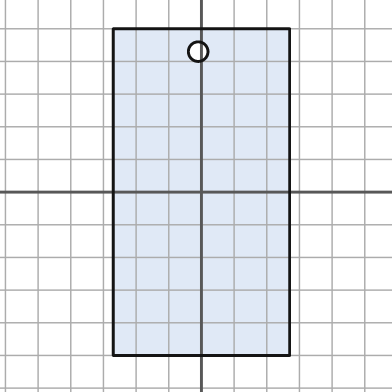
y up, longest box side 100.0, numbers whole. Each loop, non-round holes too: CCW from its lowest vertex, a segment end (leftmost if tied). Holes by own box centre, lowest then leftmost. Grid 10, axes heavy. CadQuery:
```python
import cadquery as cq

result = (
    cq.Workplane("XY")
    .moveTo(-27.0, -50.0)
    .lineTo(27.0, -50.0)
    .lineTo(27.0, 50.0)
    .lineTo(-27.0, 50.0)
    .close()
    .moveTo(-1.0, 43.0)
    .circle(3.0)
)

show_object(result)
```